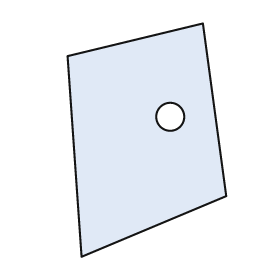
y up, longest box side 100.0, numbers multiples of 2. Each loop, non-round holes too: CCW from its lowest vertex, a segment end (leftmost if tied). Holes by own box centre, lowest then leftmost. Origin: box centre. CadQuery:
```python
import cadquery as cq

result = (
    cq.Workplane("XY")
    .moveTo(-28.0, -50.0)
    .lineTo(34.0, -24.0)
    .lineTo(24.0, 50.0)
    .lineTo(-34.0, 36.0)
    .close()
    .moveTo(10.0, 10.0)
    .circle(6.0)
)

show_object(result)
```